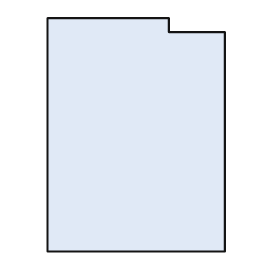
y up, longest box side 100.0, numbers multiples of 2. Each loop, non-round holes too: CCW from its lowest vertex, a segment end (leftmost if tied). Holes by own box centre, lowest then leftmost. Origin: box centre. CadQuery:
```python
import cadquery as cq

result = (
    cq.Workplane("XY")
    .moveTo(-38.0, -50.0)
    .lineTo(38.0, -50.0)
    .lineTo(38.0, 44.0)
    .lineTo(14.0, 44.0)
    .lineTo(14.0, 50.0)
    .lineTo(-38.0, 50.0)
    .close()
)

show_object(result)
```